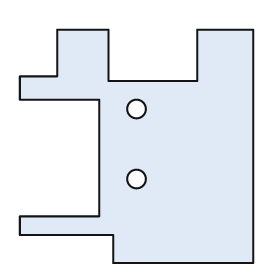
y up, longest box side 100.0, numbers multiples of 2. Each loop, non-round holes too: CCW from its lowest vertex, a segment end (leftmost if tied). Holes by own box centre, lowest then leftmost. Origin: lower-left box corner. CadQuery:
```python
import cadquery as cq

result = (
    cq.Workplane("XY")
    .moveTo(40.0, 0.0)
    .lineTo(100.0, 0.0)
    .lineTo(100.0, 100.0)
    .lineTo(76.0, 100.0)
    .lineTo(76.0, 78.0)
    .lineTo(38.0, 78.0)
    .lineTo(38.0, 100.0)
    .lineTo(16.0, 100.0)
    .lineTo(16.0, 80.0)
    .lineTo(0.0, 80.0)
    .lineTo(0.0, 70.0)
    .lineTo(34.0, 70.0)
    .lineTo(34.0, 20.0)
    .lineTo(0.0, 20.0)
    .lineTo(0.0, 12.0)
    .lineTo(40.0, 12.0)
    .close()
    .moveTo(50.0, 36.0)
    .circle(4.0)
    .moveTo(50.0, 66.0)
    .circle(4.0)
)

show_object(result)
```